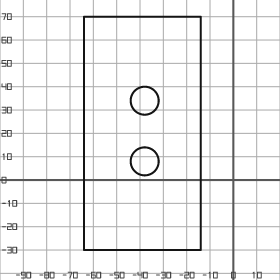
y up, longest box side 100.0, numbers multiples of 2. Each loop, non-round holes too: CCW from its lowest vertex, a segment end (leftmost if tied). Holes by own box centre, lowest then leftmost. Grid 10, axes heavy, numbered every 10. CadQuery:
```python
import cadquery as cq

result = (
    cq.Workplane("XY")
    .moveTo(-64.0, -30.0)
    .lineTo(-14.0, -30.0)
    .lineTo(-14.0, 70.0)
    .lineTo(-64.0, 70.0)
    .close()
    .moveTo(-38.0, 8.0)
    .circle(6.0)
    .moveTo(-38.0, 34.0)
    .circle(6.0)
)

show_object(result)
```